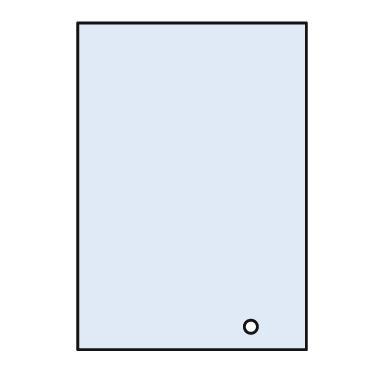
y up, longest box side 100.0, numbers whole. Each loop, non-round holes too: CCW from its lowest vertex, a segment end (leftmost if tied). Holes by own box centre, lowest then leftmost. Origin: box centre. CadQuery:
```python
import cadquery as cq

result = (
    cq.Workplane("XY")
    .moveTo(-35.0, -50.0)
    .lineTo(35.0, -50.0)
    .lineTo(35.0, 50.0)
    .lineTo(-35.0, 50.0)
    .close()
    .moveTo(18.0, -43.0)
    .circle(2.0)
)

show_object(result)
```